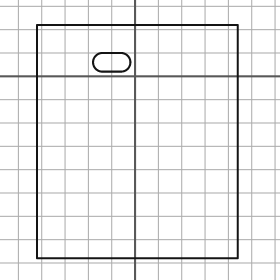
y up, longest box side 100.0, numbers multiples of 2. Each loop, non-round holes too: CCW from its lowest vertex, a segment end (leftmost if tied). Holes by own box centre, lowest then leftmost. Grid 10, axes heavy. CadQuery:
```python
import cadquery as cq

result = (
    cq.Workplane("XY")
    .moveTo(-42.0, -78.0)
    .lineTo(44.0, -78.0)
    .lineTo(44.0, 22.0)
    .lineTo(-42.0, 22.0)
    .close()
    .moveTo(-14.0, 2.0)
    .lineTo(-6.0, 2.0)
    .threePointArc((-2.0, 6.0), (-6.0, 10.0))
    .lineTo(-14.0, 10.0)
    .threePointArc((-18.0, 6.0), (-14.0, 2.0))
    .close()
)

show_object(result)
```